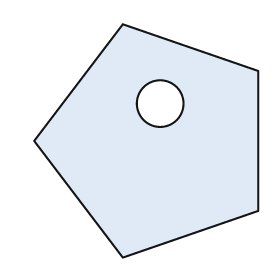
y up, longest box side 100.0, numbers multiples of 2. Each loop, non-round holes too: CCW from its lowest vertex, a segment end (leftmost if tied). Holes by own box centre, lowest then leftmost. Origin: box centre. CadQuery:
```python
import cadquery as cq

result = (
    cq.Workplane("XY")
    .moveTo(-10.0, -50.0)
    .lineTo(48.0, -30.0)
    .lineTo(48.0, 30.0)
    .lineTo(-10.0, 50.0)
    .lineTo(-48.0, 0.0)
    .close()
    .moveTo(6.0, 16.0)
    .circle(10.0)
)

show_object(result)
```